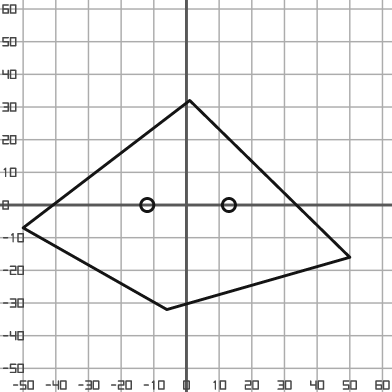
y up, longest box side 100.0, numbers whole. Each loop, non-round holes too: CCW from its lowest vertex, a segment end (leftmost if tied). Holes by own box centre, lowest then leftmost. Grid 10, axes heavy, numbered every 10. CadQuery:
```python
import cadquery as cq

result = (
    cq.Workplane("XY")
    .moveTo(-6.0, -32.0)
    .lineTo(50.0, -16.0)
    .lineTo(1.0, 32.0)
    .lineTo(-50.0, -7.0)
    .close()
    .moveTo(-12.0, 0.0)
    .circle(2.0)
    .moveTo(13.0, 0.0)
    .circle(2.0)
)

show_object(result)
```